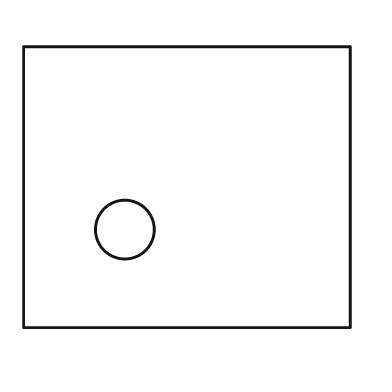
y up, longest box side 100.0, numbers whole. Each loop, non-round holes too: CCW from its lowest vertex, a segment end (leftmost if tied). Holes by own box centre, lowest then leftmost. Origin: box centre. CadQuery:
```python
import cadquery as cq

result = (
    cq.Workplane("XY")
    .moveTo(-50.0, -43.0)
    .lineTo(50.0, -43.0)
    .lineTo(50.0, 43.0)
    .lineTo(-50.0, 43.0)
    .close()
    .moveTo(-19.0, -13.0)
    .circle(9.0)
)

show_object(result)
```